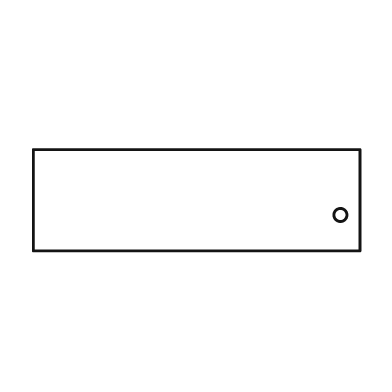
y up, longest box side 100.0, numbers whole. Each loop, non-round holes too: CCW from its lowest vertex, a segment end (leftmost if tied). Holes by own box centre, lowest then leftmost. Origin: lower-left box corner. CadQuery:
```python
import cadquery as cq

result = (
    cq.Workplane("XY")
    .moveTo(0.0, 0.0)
    .lineTo(100.0, 0.0)
    .lineTo(100.0, 31.0)
    .lineTo(0.0, 31.0)
    .close()
    .moveTo(94.0, 11.0)
    .circle(2.0)
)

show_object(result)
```